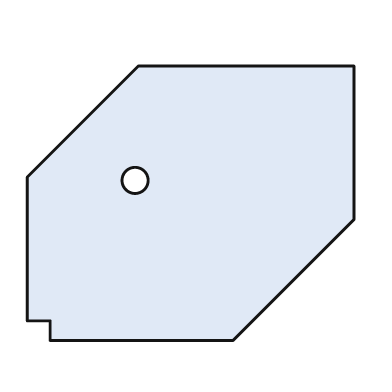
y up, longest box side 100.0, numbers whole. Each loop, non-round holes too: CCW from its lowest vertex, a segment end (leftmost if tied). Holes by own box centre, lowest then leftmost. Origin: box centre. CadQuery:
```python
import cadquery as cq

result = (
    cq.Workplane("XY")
    .moveTo(-43.0, -42.0)
    .lineTo(13.0, -42.0)
    .lineTo(50.0, -5.0)
    .lineTo(50.0, 42.0)
    .lineTo(-16.0, 42.0)
    .lineTo(-50.0, 8.0)
    .lineTo(-50.0, -36.0)
    .lineTo(-43.0, -36.0)
    .close()
    .moveTo(-17.0, 7.0)
    .circle(4.0)
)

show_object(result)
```